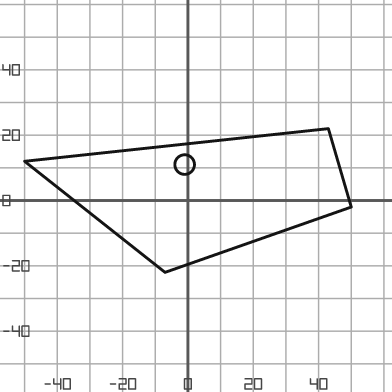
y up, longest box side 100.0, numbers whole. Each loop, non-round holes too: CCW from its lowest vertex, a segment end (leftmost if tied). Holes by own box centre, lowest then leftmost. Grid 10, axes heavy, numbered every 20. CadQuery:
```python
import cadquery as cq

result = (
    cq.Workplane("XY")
    .moveTo(-7.0, -22.0)
    .lineTo(50.0, -2.0)
    .lineTo(43.0, 22.0)
    .lineTo(-50.0, 12.0)
    .close()
    .moveTo(-1.0, 11.0)
    .circle(3.0)
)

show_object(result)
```